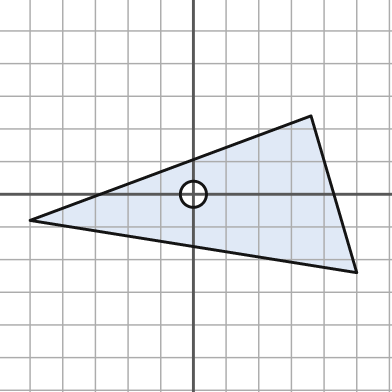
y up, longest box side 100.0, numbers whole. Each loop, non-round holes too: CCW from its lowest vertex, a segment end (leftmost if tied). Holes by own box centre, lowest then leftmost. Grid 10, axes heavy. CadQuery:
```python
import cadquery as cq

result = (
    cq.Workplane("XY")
    .moveTo(50.0, -24.0)
    .lineTo(36.0, 24.0)
    .lineTo(-50.0, -8.0)
    .close()
    .moveTo(0.0, 0.0)
    .circle(4.0)
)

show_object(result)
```